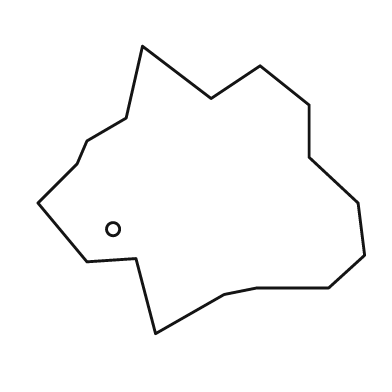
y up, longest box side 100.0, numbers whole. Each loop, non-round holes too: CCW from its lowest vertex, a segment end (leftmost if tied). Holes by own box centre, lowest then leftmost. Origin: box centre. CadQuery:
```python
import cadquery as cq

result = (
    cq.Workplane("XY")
    .moveTo(-14.0, -44.0)
    .lineTo(7.0, -32.0)
    .lineTo(17.0, -30.0)
    .lineTo(39.0, -30.0)
    .lineTo(50.0, -20.0)
    .lineTo(48.0, -4.0)
    .lineTo(33.0, 10.0)
    .lineTo(33.0, 26.0)
    .lineTo(18.0, 38.0)
    .lineTo(3.0, 28.0)
    .lineTo(-18.0, 44.0)
    .lineTo(-23.0, 22.0)
    .lineTo(-35.0, 15.0)
    .lineTo(-38.0, 8.0)
    .lineTo(-50.0, -4.0)
    .lineTo(-35.0, -22.0)
    .lineTo(-20.0, -21.0)
    .close()
    .moveTo(-27.0, -12.0)
    .circle(2.0)
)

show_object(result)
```